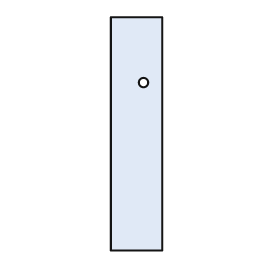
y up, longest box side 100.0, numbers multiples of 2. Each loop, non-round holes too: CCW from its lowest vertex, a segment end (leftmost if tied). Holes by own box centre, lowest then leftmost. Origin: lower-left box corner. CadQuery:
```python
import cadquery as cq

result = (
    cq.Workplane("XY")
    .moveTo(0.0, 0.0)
    .lineTo(22.0, 0.0)
    .lineTo(22.0, 100.0)
    .lineTo(0.0, 100.0)
    .close()
    .moveTo(14.0, 72.0)
    .circle(2.0)
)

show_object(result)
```